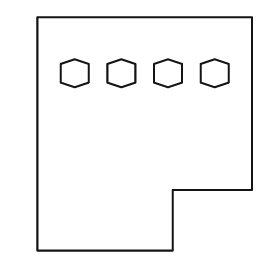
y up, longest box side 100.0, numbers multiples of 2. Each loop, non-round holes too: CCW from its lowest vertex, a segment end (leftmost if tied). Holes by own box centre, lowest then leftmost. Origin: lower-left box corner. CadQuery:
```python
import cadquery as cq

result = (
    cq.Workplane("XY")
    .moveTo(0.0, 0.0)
    .lineTo(58.0, 0.0)
    .lineTo(58.0, 26.0)
    .lineTo(92.0, 26.0)
    .lineTo(92.0, 100.0)
    .lineTo(0.0, 100.0)
    .close()
    .moveTo(16.0, 70.0)
    .lineTo(22.0, 72.0)
    .lineTo(22.0, 80.0)
    .lineTo(16.0, 82.0)
    .lineTo(10.0, 80.0)
    .lineTo(10.0, 72.0)
    .close()
    .moveTo(36.0, 70.0)
    .lineTo(42.0, 72.0)
    .lineTo(42.0, 80.0)
    .lineTo(36.0, 82.0)
    .lineTo(30.0, 80.0)
    .lineTo(30.0, 72.0)
    .close()
    .moveTo(56.0, 70.0)
    .lineTo(62.0, 72.0)
    .lineTo(62.0, 80.0)
    .lineTo(56.0, 82.0)
    .lineTo(50.0, 80.0)
    .lineTo(50.0, 72.0)
    .close()
    .moveTo(76.0, 70.0)
    .lineTo(82.0, 72.0)
    .lineTo(82.0, 80.0)
    .lineTo(76.0, 82.0)
    .lineTo(70.0, 80.0)
    .lineTo(70.0, 72.0)
    .close()
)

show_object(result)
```